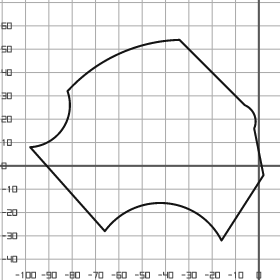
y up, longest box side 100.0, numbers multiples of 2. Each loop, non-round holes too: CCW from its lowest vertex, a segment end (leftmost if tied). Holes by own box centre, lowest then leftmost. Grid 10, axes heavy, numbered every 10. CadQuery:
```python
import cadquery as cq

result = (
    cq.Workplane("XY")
    .moveTo(-16.0, -32.0)
    .lineTo(2.0, -4.0)
    .lineTo(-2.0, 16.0)
    .threePointArc((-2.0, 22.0), (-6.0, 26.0))
    .lineTo(-34.0, 54.0)
    .threePointArc((-60.0, 48.0), (-82.0, 32.0))
    .threePointArc((-84.0, 16.0), (-98.0, 8.0))
    .lineTo(-66.0, -28.0)
    .threePointArc((-40.0, -16.0), (-16.0, -32.0))
    .close()
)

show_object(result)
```